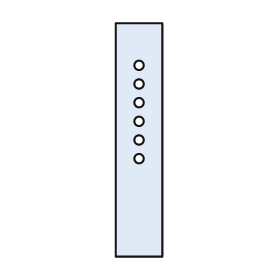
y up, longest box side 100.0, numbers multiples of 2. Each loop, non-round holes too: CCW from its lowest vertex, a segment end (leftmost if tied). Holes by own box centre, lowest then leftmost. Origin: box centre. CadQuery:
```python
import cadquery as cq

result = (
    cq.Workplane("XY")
    .moveTo(-10.0, -50.0)
    .lineTo(10.0, -50.0)
    .lineTo(10.0, 50.0)
    .lineTo(-10.0, 50.0)
    .close()
    .moveTo(0.0, -8.0)
    .circle(2.0)
    .moveTo(0.0, 0.0)
    .circle(2.0)
    .moveTo(0.0, 8.0)
    .circle(2.0)
    .moveTo(0.0, 16.0)
    .circle(2.0)
    .moveTo(0.0, 24.0)
    .circle(2.0)
    .moveTo(0.0, 32.0)
    .circle(2.0)
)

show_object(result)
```